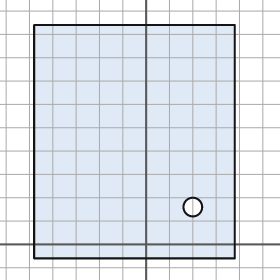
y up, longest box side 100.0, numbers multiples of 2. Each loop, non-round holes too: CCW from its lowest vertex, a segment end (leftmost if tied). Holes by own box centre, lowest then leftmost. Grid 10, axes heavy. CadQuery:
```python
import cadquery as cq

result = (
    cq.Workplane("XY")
    .moveTo(-48.0, -6.0)
    .lineTo(38.0, -6.0)
    .lineTo(38.0, 94.0)
    .lineTo(-48.0, 94.0)
    .close()
    .moveTo(20.0, 16.0)
    .circle(4.0)
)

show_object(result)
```